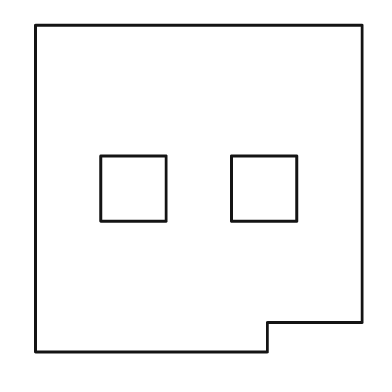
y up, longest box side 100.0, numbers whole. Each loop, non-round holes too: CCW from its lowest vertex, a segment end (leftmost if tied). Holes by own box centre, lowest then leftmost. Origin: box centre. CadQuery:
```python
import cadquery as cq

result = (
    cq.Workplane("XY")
    .moveTo(-50.0, -50.0)
    .lineTo(21.0, -50.0)
    .lineTo(21.0, -41.0)
    .lineTo(50.0, -41.0)
    .lineTo(50.0, 50.0)
    .lineTo(-50.0, 50.0)
    .close()
    .moveTo(-30.0, -10.0)
    .lineTo(-10.0, -10.0)
    .lineTo(-10.0, 10.0)
    .lineTo(-30.0, 10.0)
    .close()
    .moveTo(10.0, -10.0)
    .lineTo(30.0, -10.0)
    .lineTo(30.0, 10.0)
    .lineTo(10.0, 10.0)
    .close()
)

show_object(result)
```